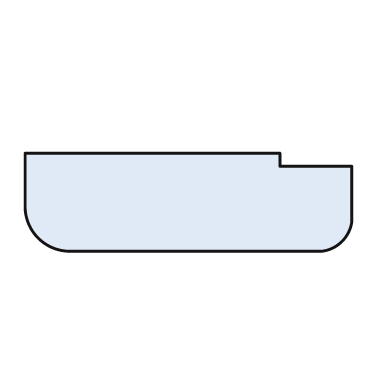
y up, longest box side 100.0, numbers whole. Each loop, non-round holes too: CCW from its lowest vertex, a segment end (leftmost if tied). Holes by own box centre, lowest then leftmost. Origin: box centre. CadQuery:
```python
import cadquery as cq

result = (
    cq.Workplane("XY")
    .moveTo(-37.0, -15.0)
    .lineTo(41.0, -15.0)
    .threePointArc((47.0, -12.0), (50.0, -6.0))
    .lineTo(50.0, 11.0)
    .lineTo(28.0, 11.0)
    .lineTo(28.0, 15.0)
    .lineTo(-50.0, 15.0)
    .lineTo(-50.0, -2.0)
    .threePointArc((-46.0, -11.0), (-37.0, -15.0))
    .close()
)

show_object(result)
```